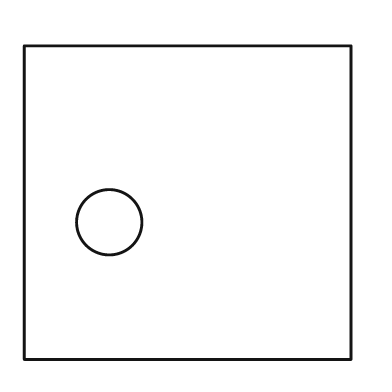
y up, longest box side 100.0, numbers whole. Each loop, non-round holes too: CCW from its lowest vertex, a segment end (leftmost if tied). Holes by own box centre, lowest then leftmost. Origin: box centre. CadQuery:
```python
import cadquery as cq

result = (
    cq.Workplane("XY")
    .moveTo(-50.0, -48.0)
    .lineTo(50.0, -48.0)
    .lineTo(50.0, 48.0)
    .lineTo(-50.0, 48.0)
    .close()
    .moveTo(-24.0, -6.0)
    .circle(10.0)
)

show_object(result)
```